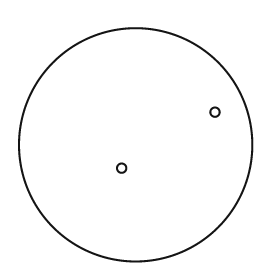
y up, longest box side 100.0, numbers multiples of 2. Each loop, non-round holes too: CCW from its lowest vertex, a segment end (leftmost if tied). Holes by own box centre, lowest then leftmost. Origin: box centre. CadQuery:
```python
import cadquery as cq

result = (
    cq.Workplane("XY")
    .moveTo(0.0, 0.0)
    .circle(50.0)
    .moveTo(-6.0, -10.0)
    .circle(2.0)
    .moveTo(34.0, 14.0)
    .circle(2.0)
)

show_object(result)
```